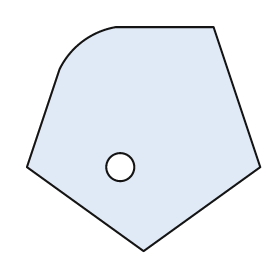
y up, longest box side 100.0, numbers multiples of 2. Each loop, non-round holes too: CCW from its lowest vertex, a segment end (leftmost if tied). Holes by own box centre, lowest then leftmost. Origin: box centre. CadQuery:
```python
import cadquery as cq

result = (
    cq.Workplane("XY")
    .moveTo(0.0, -48.0)
    .lineTo(50.0, -12.0)
    .lineTo(30.0, 48.0)
    .lineTo(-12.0, 48.0)
    .threePointArc((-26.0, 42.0), (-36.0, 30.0))
    .lineTo(-50.0, -12.0)
    .close()
    .moveTo(-10.0, -12.0)
    .circle(6.0)
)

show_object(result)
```